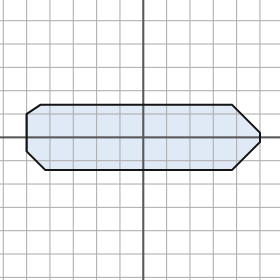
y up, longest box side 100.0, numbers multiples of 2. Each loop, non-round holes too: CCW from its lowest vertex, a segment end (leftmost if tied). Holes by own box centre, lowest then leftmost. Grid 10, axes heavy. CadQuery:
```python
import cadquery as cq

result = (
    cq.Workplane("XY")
    .moveTo(-42.0, -14.0)
    .lineTo(38.0, -14.0)
    .lineTo(50.0, -2.0)
    .lineTo(50.0, 2.0)
    .lineTo(38.0, 14.0)
    .lineTo(-44.0, 14.0)
    .lineTo(-50.0, 10.0)
    .lineTo(-50.0, -6.0)
    .close()
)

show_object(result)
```